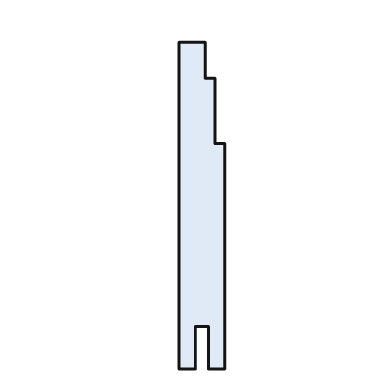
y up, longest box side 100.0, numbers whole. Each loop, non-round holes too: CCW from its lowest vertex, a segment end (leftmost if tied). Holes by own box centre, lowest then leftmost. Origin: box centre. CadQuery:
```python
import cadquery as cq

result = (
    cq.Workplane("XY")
    .moveTo(-7.0, -50.0)
    .lineTo(-2.0, -50.0)
    .lineTo(-2.0, -37.0)
    .lineTo(2.0, -37.0)
    .lineTo(2.0, -50.0)
    .lineTo(7.0, -50.0)
    .lineTo(7.0, 19.0)
    .lineTo(4.0, 19.0)
    .lineTo(4.0, 39.0)
    .lineTo(1.0, 39.0)
    .lineTo(1.0, 50.0)
    .lineTo(-7.0, 50.0)
    .close()
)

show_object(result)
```